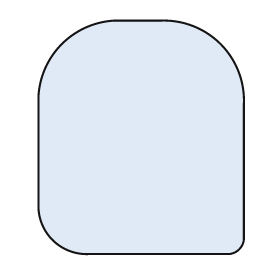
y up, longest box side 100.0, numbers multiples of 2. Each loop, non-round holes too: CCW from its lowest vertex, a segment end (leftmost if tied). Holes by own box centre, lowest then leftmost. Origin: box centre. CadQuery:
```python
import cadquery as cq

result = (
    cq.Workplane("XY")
    .moveTo(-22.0, -50.0)
    .lineTo(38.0, -50.0)
    .threePointArc((42.0, -48.0), (44.0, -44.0))
    .lineTo(44.0, 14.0)
    .threePointArc((34.0, 40.0), (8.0, 50.0))
    .lineTo(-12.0, 50.0)
    .threePointArc((-34.0, 40.0), (-44.0, 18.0))
    .lineTo(-44.0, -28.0)
    .threePointArc((-38.0, -44.0), (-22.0, -50.0))
    .close()
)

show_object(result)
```